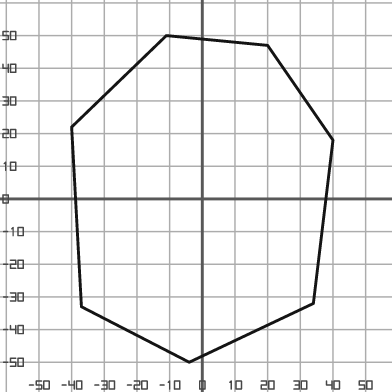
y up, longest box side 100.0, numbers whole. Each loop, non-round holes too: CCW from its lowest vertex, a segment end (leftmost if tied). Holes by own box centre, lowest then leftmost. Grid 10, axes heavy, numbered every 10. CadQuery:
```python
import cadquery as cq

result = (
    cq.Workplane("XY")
    .moveTo(-4.0, -50.0)
    .lineTo(34.0, -32.0)
    .lineTo(40.0, 18.0)
    .lineTo(20.0, 47.0)
    .lineTo(-11.0, 50.0)
    .lineTo(-40.0, 22.0)
    .lineTo(-37.0, -33.0)
    .close()
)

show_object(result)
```